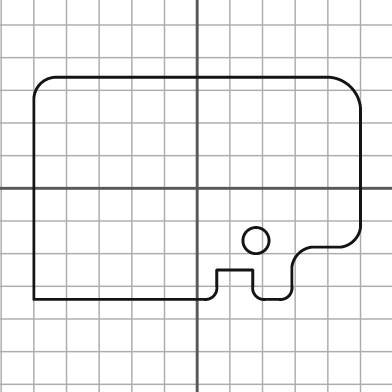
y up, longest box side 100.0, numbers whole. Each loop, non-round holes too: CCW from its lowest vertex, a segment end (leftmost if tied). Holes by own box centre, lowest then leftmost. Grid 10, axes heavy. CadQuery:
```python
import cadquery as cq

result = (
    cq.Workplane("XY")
    .moveTo(-50.0, -34.0)
    .lineTo(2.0, -34.0)
    .threePointArc((5.0, -33.0), (6.0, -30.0))
    .lineTo(6.0, -25.0)
    .lineTo(17.0, -25.0)
    .lineTo(17.0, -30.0)
    .threePointArc((18.0, -33.0), (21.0, -34.0))
    .lineTo(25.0, -34.0)
    .threePointArc((28.0, -33.0), (29.0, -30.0))
    .lineTo(29.0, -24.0)
    .threePointArc((31.0, -20.0), (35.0, -18.0))
    .lineTo(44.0, -18.0)
    .threePointArc((48.0, -16.0), (50.0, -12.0))
    .lineTo(50.0, 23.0)
    .threePointArc((47.0, 31.0), (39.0, 34.0))
    .lineTo(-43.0, 34.0)
    .threePointArc((-48.0, 32.0), (-50.0, 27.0))
    .close()
    .moveTo(18.0, -16.0)
    .circle(4.0)
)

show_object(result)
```